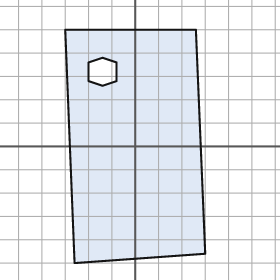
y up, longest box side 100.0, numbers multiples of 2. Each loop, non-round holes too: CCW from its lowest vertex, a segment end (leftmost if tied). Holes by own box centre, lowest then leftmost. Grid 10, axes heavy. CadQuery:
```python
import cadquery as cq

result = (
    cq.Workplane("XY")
    .moveTo(-26.0, -50.0)
    .lineTo(30.0, -46.0)
    .lineTo(26.0, 50.0)
    .lineTo(-30.0, 50.0)
    .close()
    .moveTo(-14.0, 26.0)
    .lineTo(-8.0, 28.0)
    .lineTo(-8.0, 36.0)
    .lineTo(-14.0, 38.0)
    .lineTo(-20.0, 36.0)
    .lineTo(-20.0, 28.0)
    .close()
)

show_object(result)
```